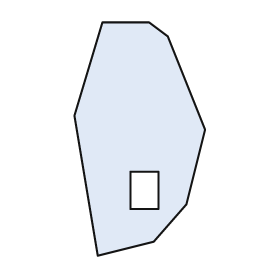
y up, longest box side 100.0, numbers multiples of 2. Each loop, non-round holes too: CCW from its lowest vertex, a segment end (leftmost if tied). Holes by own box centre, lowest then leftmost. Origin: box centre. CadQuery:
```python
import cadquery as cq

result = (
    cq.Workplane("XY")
    .moveTo(-18.0, -50.0)
    .lineTo(6.0, -44.0)
    .lineTo(20.0, -28.0)
    .lineTo(28.0, 4.0)
    .lineTo(12.0, 44.0)
    .lineTo(4.0, 50.0)
    .lineTo(-16.0, 50.0)
    .lineTo(-28.0, 10.0)
    .close()
    .moveTo(-4.0, -30.0)
    .lineTo(8.0, -30.0)
    .lineTo(8.0, -14.0)
    .lineTo(-4.0, -14.0)
    .close()
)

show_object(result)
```